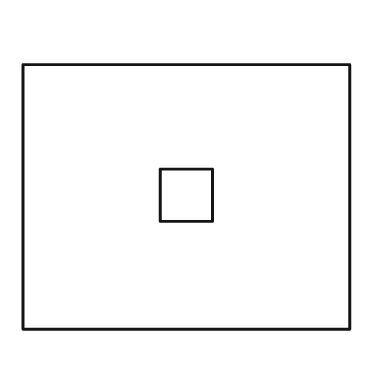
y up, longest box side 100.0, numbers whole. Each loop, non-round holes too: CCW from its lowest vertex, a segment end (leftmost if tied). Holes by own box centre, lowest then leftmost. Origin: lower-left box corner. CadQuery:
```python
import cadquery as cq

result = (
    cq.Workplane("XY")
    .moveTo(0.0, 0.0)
    .lineTo(100.0, 0.0)
    .lineTo(100.0, 81.0)
    .lineTo(0.0, 81.0)
    .close()
    .moveTo(42.0, 33.0)
    .lineTo(58.0, 33.0)
    .lineTo(58.0, 49.0)
    .lineTo(42.0, 49.0)
    .close()
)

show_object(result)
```